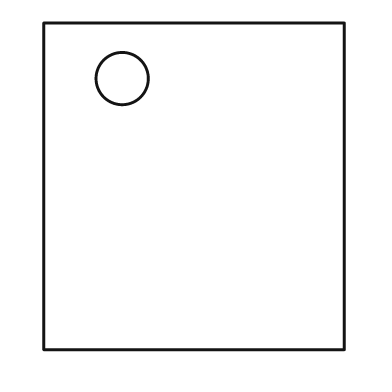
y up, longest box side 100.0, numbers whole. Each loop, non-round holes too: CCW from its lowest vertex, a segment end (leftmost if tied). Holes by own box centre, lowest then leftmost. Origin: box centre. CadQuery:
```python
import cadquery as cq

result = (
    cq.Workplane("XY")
    .moveTo(-46.0, -50.0)
    .lineTo(46.0, -50.0)
    .lineTo(46.0, 50.0)
    .lineTo(-46.0, 50.0)
    .close()
    .moveTo(-22.0, 33.0)
    .circle(8.0)
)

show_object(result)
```